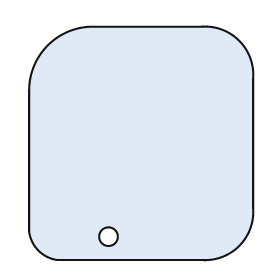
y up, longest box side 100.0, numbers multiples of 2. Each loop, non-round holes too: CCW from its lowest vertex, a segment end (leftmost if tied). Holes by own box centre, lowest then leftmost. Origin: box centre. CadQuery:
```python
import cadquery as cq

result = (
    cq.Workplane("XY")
    .moveTo(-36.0, -50.0)
    .lineTo(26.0, -50.0)
    .threePointArc((42.0, -44.0), (48.0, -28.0))
    .lineTo(48.0, 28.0)
    .threePointArc((42.0, 44.0), (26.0, 50.0))
    .lineTo(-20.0, 50.0)
    .threePointArc((-40.0, 42.0), (-48.0, 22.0))
    .lineTo(-48.0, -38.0)
    .threePointArc((-44.0, -46.0), (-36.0, -50.0))
    .close()
    .moveTo(-14.0, -40.0)
    .circle(4.0)
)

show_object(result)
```